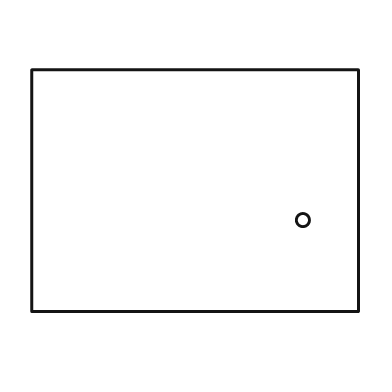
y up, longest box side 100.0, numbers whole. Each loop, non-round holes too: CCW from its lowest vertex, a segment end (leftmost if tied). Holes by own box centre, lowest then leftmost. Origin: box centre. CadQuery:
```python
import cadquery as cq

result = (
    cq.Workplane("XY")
    .moveTo(-50.0, -37.0)
    .lineTo(50.0, -37.0)
    .lineTo(50.0, 37.0)
    .lineTo(-50.0, 37.0)
    .close()
    .moveTo(33.0, -9.0)
    .circle(2.0)
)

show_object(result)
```